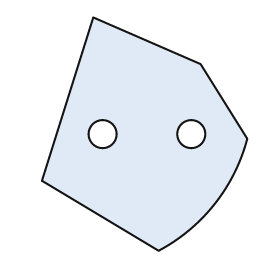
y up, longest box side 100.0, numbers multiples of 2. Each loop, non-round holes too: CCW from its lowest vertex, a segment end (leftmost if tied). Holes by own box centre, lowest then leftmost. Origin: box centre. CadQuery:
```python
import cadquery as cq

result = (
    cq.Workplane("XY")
    .moveTo(6.0, -50.0)
    .threePointArc((30.0, -30.0), (44.0, -2.0))
    .lineTo(24.0, 30.0)
    .lineTo(-22.0, 50.0)
    .lineTo(-44.0, -20.0)
    .close()
    .moveTo(-18.0, 0.0)
    .circle(6.0)
    .moveTo(20.0, 0.0)
    .circle(6.0)
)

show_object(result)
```